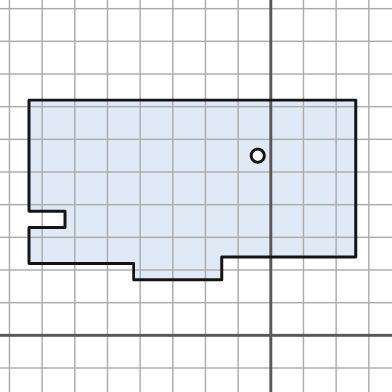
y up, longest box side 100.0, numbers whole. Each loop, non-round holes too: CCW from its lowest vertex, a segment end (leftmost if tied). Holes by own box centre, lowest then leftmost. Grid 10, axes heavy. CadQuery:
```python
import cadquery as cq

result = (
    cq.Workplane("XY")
    .moveTo(-42.0, 17.0)
    .lineTo(-15.0, 17.0)
    .lineTo(-15.0, 24.0)
    .lineTo(26.0, 24.0)
    .lineTo(26.0, 72.0)
    .lineTo(-74.0, 72.0)
    .lineTo(-74.0, 38.0)
    .lineTo(-63.0, 38.0)
    .lineTo(-63.0, 33.0)
    .lineTo(-74.0, 33.0)
    .lineTo(-74.0, 22.0)
    .lineTo(-42.0, 22.0)
    .close()
    .moveTo(-4.0, 55.0)
    .circle(2.0)
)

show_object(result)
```